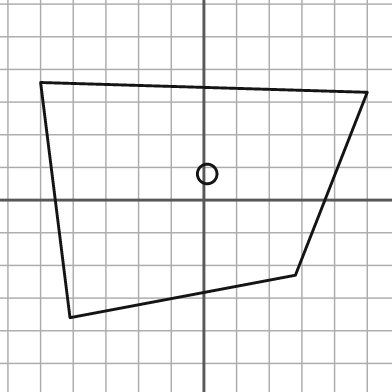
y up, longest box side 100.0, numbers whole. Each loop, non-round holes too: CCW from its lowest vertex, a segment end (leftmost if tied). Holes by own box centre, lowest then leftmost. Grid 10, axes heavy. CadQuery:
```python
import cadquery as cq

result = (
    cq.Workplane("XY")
    .moveTo(-41.0, -36.0)
    .lineTo(28.0, -23.0)
    .lineTo(50.0, 33.0)
    .lineTo(-50.0, 36.0)
    .close()
    .moveTo(1.0, 8.0)
    .circle(3.0)
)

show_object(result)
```